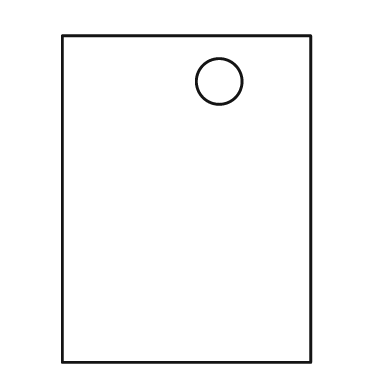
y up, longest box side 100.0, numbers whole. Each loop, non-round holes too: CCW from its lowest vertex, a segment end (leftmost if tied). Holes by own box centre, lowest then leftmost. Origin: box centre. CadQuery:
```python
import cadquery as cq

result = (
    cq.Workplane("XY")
    .moveTo(-38.0, -50.0)
    .lineTo(38.0, -50.0)
    .lineTo(38.0, 50.0)
    .lineTo(-38.0, 50.0)
    .close()
    .moveTo(10.0, 36.0)
    .circle(7.0)
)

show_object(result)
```